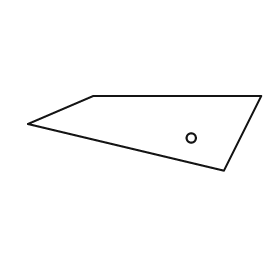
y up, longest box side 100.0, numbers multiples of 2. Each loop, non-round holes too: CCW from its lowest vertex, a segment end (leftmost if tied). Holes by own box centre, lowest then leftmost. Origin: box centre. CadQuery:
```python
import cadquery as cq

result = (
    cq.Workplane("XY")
    .moveTo(34.0, -16.0)
    .lineTo(50.0, 16.0)
    .lineTo(-22.0, 16.0)
    .lineTo(-50.0, 4.0)
    .close()
    .moveTo(20.0, -2.0)
    .circle(2.0)
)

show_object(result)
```